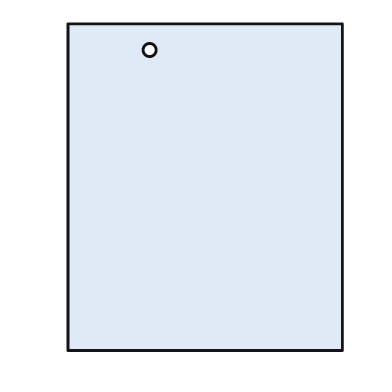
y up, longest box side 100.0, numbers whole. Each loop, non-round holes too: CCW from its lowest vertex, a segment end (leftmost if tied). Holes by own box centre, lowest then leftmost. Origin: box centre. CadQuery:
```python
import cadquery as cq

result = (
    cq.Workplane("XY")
    .moveTo(-42.0, -50.0)
    .lineTo(42.0, -50.0)
    .lineTo(42.0, 50.0)
    .lineTo(-42.0, 50.0)
    .close()
    .moveTo(-17.0, 42.0)
    .circle(2.0)
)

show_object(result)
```